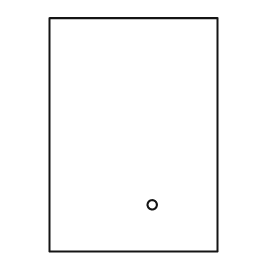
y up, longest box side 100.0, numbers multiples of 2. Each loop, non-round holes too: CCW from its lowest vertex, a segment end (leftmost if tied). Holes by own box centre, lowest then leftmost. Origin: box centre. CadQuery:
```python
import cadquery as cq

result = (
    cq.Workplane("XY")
    .moveTo(-36.0, -50.0)
    .lineTo(36.0, -50.0)
    .lineTo(36.0, 50.0)
    .lineTo(-36.0, 50.0)
    .close()
    .moveTo(8.0, -30.0)
    .circle(2.0)
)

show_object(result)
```